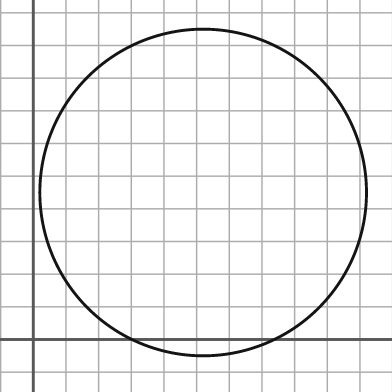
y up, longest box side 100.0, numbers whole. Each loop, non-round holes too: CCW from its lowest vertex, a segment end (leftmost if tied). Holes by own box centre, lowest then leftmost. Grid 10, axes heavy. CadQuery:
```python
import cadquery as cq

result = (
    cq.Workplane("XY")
    .moveTo(52.0, 45.0)
    .circle(50.0)
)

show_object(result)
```